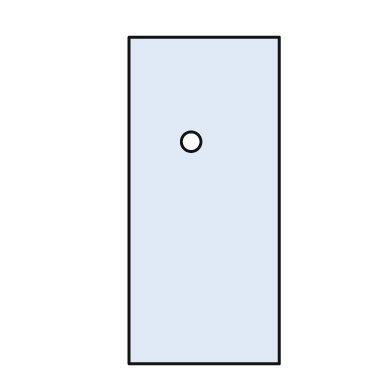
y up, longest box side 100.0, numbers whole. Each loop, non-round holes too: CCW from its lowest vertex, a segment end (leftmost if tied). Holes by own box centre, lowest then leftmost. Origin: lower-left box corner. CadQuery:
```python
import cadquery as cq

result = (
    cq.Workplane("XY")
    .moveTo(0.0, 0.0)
    .lineTo(46.0, 0.0)
    .lineTo(46.0, 100.0)
    .lineTo(0.0, 100.0)
    .close()
    .moveTo(19.0, 68.0)
    .circle(3.0)
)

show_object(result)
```